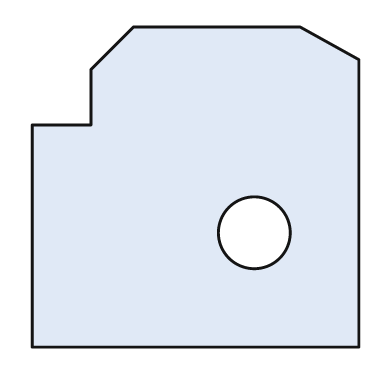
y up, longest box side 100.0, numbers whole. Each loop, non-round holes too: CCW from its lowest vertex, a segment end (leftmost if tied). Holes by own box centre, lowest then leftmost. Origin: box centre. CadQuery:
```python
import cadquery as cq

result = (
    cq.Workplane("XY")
    .moveTo(-50.0, -49.0)
    .lineTo(50.0, -49.0)
    .lineTo(50.0, 39.0)
    .lineTo(32.0, 49.0)
    .lineTo(-19.0, 49.0)
    .lineTo(-32.0, 36.0)
    .lineTo(-32.0, 19.0)
    .lineTo(-50.0, 19.0)
    .close()
    .moveTo(18.0, -14.0)
    .circle(11.0)
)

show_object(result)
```